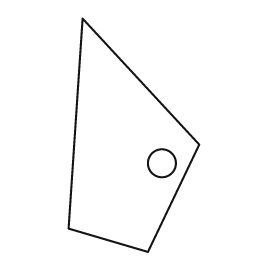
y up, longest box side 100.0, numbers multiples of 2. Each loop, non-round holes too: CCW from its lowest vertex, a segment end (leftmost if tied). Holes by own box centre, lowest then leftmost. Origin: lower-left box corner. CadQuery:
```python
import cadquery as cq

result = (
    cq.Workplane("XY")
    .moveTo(34.0, 0.0)
    .lineTo(56.0, 46.0)
    .lineTo(6.0, 100.0)
    .lineTo(0.0, 10.0)
    .close()
    .moveTo(40.0, 38.0)
    .circle(6.0)
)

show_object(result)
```